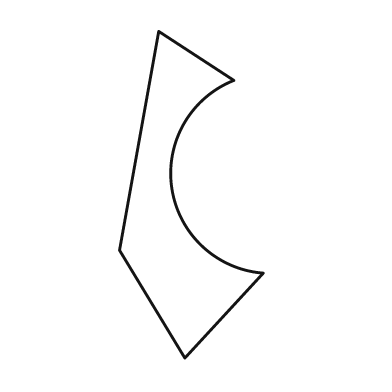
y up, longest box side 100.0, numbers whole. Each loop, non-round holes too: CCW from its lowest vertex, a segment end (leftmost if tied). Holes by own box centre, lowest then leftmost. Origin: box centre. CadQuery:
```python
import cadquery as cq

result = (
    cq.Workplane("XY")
    .moveTo(-2.0, -50.0)
    .lineTo(22.0, -24.0)
    .threePointArc((-6.0, 2.0), (13.0, 35.0))
    .lineTo(-10.0, 50.0)
    .lineTo(-22.0, -17.0)
    .close()
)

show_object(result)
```